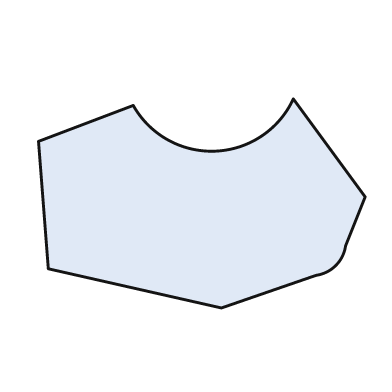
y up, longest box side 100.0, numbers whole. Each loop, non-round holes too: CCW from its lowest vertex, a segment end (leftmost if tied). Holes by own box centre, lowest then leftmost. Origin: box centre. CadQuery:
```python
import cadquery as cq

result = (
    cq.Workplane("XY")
    .moveTo(6.0, -32.0)
    .lineTo(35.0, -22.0)
    .threePointArc((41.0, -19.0), (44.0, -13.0))
    .lineTo(50.0, 2.0)
    .lineTo(28.0, 32.0)
    .threePointArc((4.0, 16.0), (-21.0, 30.0))
    .lineTo(-50.0, 19.0)
    .lineTo(-47.0, -20.0)
    .close()
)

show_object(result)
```